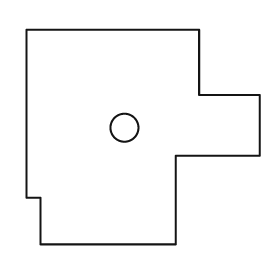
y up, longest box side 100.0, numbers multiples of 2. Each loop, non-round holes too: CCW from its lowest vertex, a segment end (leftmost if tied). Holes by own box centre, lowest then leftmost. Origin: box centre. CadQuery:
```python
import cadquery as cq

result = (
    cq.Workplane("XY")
    .moveTo(-44.0, -46.0)
    .lineTo(14.0, -46.0)
    .lineTo(14.0, -8.0)
    .lineTo(50.0, -8.0)
    .lineTo(50.0, 18.0)
    .lineTo(24.0, 18.0)
    .lineTo(24.0, 46.0)
    .lineTo(-50.0, 46.0)
    .lineTo(-50.0, -26.0)
    .lineTo(-44.0, -26.0)
    .close()
    .moveTo(-8.0, 4.0)
    .circle(6.0)
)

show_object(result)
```